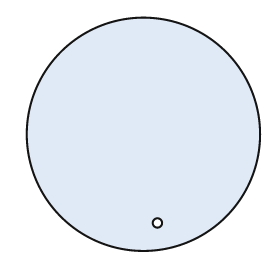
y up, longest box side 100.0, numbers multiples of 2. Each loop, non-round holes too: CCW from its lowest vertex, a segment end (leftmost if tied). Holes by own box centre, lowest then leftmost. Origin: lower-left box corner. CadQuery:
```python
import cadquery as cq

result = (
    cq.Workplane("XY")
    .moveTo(50.0, 50.0)
    .circle(50.0)
    .moveTo(56.0, 12.0)
    .circle(2.0)
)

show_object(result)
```